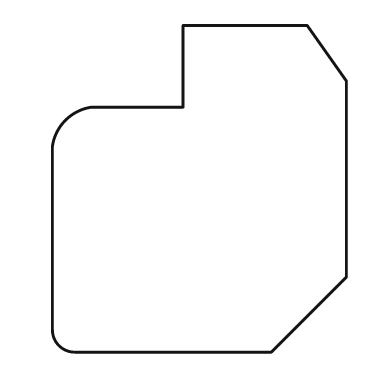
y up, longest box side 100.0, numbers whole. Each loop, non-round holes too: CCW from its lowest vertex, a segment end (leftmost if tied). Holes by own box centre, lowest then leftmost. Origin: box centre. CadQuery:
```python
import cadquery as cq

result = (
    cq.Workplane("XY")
    .moveTo(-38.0, -50.0)
    .lineTo(22.0, -50.0)
    .lineTo(45.0, -27.0)
    .lineTo(45.0, 33.0)
    .lineTo(33.0, 50.0)
    .lineTo(-5.0, 50.0)
    .lineTo(-5.0, 25.0)
    .lineTo(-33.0, 25.0)
    .threePointArc((-41.0, 21.0), (-45.0, 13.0))
    .lineTo(-45.0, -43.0)
    .threePointArc((-43.0, -48.0), (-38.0, -50.0))
    .close()
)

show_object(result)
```